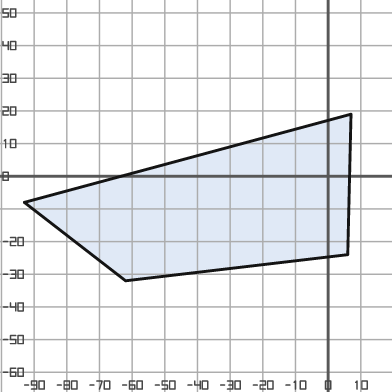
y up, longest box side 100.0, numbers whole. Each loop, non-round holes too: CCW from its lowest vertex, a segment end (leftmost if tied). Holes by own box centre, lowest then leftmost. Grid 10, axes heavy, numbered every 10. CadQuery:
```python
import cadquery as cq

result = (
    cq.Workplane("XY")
    .moveTo(-62.0, -32.0)
    .lineTo(6.0, -24.0)
    .lineTo(7.0, 19.0)
    .lineTo(-93.0, -8.0)
    .close()
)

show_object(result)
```